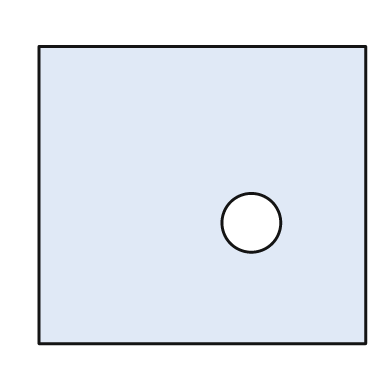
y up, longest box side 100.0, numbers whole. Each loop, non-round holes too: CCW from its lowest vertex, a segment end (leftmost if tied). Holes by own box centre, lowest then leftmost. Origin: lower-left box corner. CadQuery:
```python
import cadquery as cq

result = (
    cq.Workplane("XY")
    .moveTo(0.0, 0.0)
    .lineTo(100.0, 0.0)
    .lineTo(100.0, 91.0)
    .lineTo(0.0, 91.0)
    .close()
    .moveTo(65.0, 37.0)
    .circle(9.0)
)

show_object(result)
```